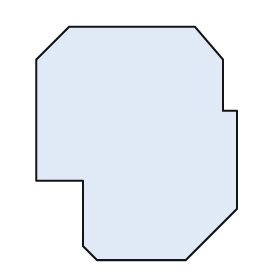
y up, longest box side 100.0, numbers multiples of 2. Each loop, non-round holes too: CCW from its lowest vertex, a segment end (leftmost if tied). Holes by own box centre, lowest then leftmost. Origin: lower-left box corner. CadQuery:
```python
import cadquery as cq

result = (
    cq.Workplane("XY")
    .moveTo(26.0, 0.0)
    .lineTo(64.0, 0.0)
    .lineTo(86.0, 22.0)
    .lineTo(86.0, 64.0)
    .lineTo(80.0, 64.0)
    .lineTo(80.0, 86.0)
    .lineTo(68.0, 100.0)
    .lineTo(14.0, 100.0)
    .lineTo(0.0, 86.0)
    .lineTo(0.0, 34.0)
    .lineTo(20.0, 34.0)
    .lineTo(20.0, 6.0)
    .close()
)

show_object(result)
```